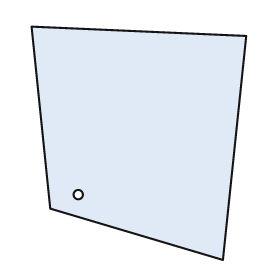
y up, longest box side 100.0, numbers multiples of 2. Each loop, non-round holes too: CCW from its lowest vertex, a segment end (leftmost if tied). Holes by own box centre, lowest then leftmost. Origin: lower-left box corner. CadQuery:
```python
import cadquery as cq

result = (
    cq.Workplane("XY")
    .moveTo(82.0, 0.0)
    .lineTo(92.0, 96.0)
    .lineTo(0.0, 100.0)
    .lineTo(8.0, 22.0)
    .close()
    .moveTo(20.0, 28.0)
    .circle(2.0)
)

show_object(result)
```